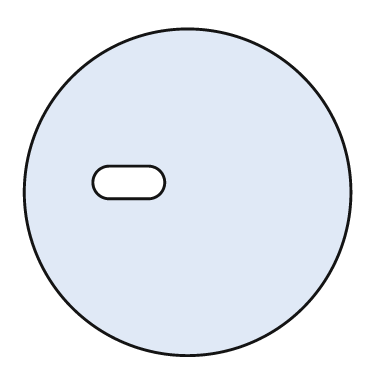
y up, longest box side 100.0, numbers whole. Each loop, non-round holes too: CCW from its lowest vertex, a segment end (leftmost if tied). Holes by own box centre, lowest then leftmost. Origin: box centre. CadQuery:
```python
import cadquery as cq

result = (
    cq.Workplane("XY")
    .moveTo(0.0, 0.0)
    .circle(50.0)
    .moveTo(-24.0, -2.0)
    .lineTo(-12.0, -2.0)
    .threePointArc((-7.0, 3.0), (-12.0, 8.0))
    .lineTo(-24.0, 8.0)
    .threePointArc((-29.0, 3.0), (-24.0, -2.0))
    .close()
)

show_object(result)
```